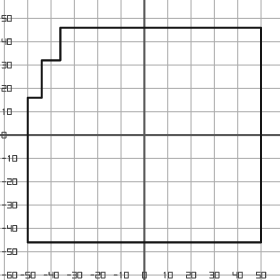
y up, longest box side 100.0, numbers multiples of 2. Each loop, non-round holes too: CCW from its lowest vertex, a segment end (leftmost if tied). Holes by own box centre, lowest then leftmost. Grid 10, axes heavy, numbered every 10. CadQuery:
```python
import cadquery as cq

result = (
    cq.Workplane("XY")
    .moveTo(-50.0, -46.0)
    .lineTo(50.0, -46.0)
    .lineTo(50.0, 46.0)
    .lineTo(-36.0, 46.0)
    .lineTo(-36.0, 32.0)
    .lineTo(-44.0, 32.0)
    .lineTo(-44.0, 16.0)
    .lineTo(-50.0, 16.0)
    .close()
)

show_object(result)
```